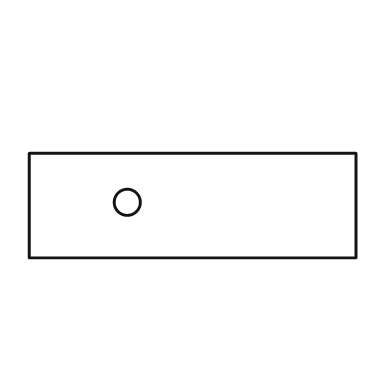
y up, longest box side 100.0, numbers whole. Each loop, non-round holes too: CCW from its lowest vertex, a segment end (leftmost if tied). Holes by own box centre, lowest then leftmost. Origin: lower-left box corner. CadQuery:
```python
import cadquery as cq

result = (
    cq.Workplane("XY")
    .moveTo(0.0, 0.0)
    .lineTo(100.0, 0.0)
    .lineTo(100.0, 32.0)
    .lineTo(0.0, 32.0)
    .close()
    .moveTo(30.0, 17.0)
    .circle(4.0)
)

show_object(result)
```